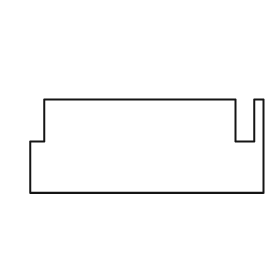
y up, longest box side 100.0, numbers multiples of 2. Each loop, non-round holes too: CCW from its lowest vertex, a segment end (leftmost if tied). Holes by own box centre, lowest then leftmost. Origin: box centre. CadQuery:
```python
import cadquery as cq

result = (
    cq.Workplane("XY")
    .moveTo(-50.0, -20.0)
    .lineTo(50.0, -20.0)
    .lineTo(50.0, 20.0)
    .lineTo(46.0, 20.0)
    .lineTo(46.0, 2.0)
    .lineTo(38.0, 2.0)
    .lineTo(38.0, 20.0)
    .lineTo(-44.0, 20.0)
    .lineTo(-44.0, 2.0)
    .lineTo(-50.0, 2.0)
    .close()
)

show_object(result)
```